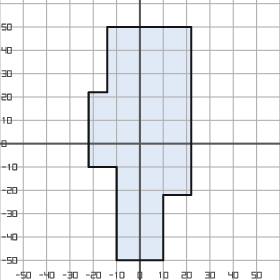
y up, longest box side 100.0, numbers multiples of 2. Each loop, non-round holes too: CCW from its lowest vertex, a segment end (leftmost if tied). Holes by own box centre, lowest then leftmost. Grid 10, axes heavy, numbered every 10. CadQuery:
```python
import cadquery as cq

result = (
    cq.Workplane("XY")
    .moveTo(-10.0, -50.0)
    .lineTo(10.0, -50.0)
    .lineTo(10.0, -22.0)
    .lineTo(22.0, -22.0)
    .lineTo(22.0, 50.0)
    .lineTo(-14.0, 50.0)
    .lineTo(-14.0, 22.0)
    .lineTo(-22.0, 22.0)
    .lineTo(-22.0, -10.0)
    .lineTo(-10.0, -10.0)
    .close()
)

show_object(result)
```